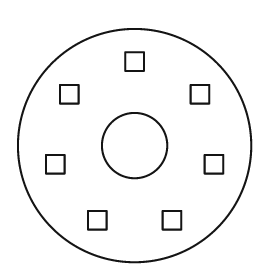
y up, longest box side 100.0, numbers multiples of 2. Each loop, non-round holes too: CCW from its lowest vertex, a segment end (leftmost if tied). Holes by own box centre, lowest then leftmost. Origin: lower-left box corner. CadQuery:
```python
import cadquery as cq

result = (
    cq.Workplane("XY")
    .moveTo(50.0, 50.0)
    .circle(50.0)
    .moveTo(30.0, 14.0)
    .lineTo(38.0, 14.0)
    .lineTo(38.0, 22.0)
    .lineTo(30.0, 22.0)
    .close()
    .moveTo(62.0, 14.0)
    .lineTo(70.0, 14.0)
    .lineTo(70.0, 22.0)
    .lineTo(62.0, 22.0)
    .close()
    .moveTo(12.0, 38.0)
    .lineTo(20.0, 38.0)
    .lineTo(20.0, 46.0)
    .lineTo(12.0, 46.0)
    .close()
    .moveTo(80.0, 38.0)
    .lineTo(88.0, 38.0)
    .lineTo(88.0, 46.0)
    .lineTo(80.0, 46.0)
    .close()
    .moveTo(50.0, 50.0)
    .circle(14.0)
    .moveTo(18.0, 68.0)
    .lineTo(26.0, 68.0)
    .lineTo(26.0, 76.0)
    .lineTo(18.0, 76.0)
    .close()
    .moveTo(74.0, 68.0)
    .lineTo(82.0, 68.0)
    .lineTo(82.0, 76.0)
    .lineTo(74.0, 76.0)
    .close()
    .moveTo(46.0, 82.0)
    .lineTo(54.0, 82.0)
    .lineTo(54.0, 90.0)
    .lineTo(46.0, 90.0)
    .close()
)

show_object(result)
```